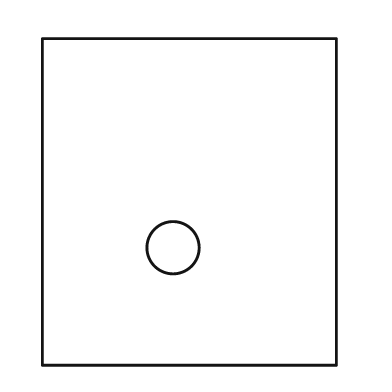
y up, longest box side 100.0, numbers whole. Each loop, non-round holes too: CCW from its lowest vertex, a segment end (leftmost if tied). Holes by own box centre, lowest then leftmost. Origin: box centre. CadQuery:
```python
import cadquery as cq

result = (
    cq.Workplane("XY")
    .moveTo(-45.0, -50.0)
    .lineTo(45.0, -50.0)
    .lineTo(45.0, 50.0)
    .lineTo(-45.0, 50.0)
    .close()
    .moveTo(-5.0, -14.0)
    .circle(8.0)
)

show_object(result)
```